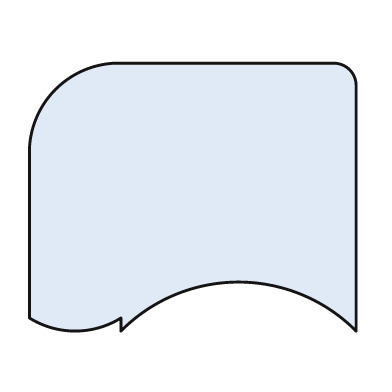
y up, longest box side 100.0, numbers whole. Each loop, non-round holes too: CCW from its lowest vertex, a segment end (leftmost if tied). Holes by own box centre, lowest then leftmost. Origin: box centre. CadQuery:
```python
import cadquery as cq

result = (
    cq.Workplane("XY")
    .moveTo(-22.0, -41.0)
    .threePointArc((14.0, -26.0), (50.0, -41.0))
    .lineTo(50.0, 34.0)
    .threePointArc((48.0, 39.0), (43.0, 41.0))
    .lineTo(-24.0, 41.0)
    .threePointArc((-42.0, 33.0), (-50.0, 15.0))
    .lineTo(-50.0, -37.0)
    .threePointArc((-36.0, -41.0), (-22.0, -37.0))
    .close()
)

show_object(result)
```